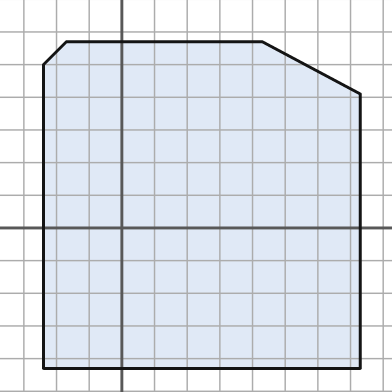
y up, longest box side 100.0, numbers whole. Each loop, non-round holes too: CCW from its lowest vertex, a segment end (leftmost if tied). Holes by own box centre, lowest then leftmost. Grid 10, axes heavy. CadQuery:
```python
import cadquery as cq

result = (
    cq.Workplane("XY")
    .moveTo(-24.0, -43.0)
    .lineTo(73.0, -43.0)
    .lineTo(73.0, 41.0)
    .lineTo(43.0, 57.0)
    .lineTo(-17.0, 57.0)
    .lineTo(-24.0, 50.0)
    .close()
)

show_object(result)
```